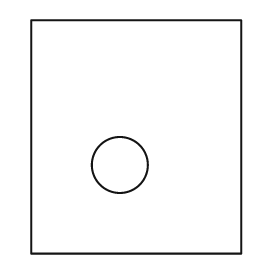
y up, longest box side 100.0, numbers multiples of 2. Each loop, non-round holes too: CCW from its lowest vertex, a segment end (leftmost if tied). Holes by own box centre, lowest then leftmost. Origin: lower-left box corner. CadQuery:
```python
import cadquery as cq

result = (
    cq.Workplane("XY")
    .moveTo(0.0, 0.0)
    .lineTo(90.0, 0.0)
    .lineTo(90.0, 100.0)
    .lineTo(0.0, 100.0)
    .close()
    .moveTo(38.0, 38.0)
    .circle(12.0)
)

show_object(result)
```